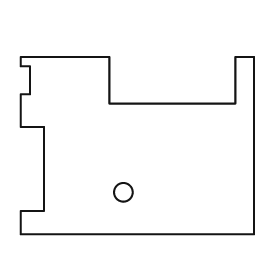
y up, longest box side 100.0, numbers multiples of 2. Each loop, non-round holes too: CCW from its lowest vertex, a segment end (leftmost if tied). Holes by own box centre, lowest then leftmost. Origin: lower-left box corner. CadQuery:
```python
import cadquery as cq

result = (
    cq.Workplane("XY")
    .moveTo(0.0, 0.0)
    .lineTo(100.0, 0.0)
    .lineTo(100.0, 76.0)
    .lineTo(92.0, 76.0)
    .lineTo(92.0, 56.0)
    .lineTo(38.0, 56.0)
    .lineTo(38.0, 76.0)
    .lineTo(0.0, 76.0)
    .lineTo(0.0, 72.0)
    .lineTo(4.0, 72.0)
    .lineTo(4.0, 60.0)
    .lineTo(0.0, 60.0)
    .lineTo(0.0, 46.0)
    .lineTo(10.0, 46.0)
    .lineTo(10.0, 10.0)
    .lineTo(0.0, 10.0)
    .close()
    .moveTo(44.0, 18.0)
    .circle(4.0)
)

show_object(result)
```